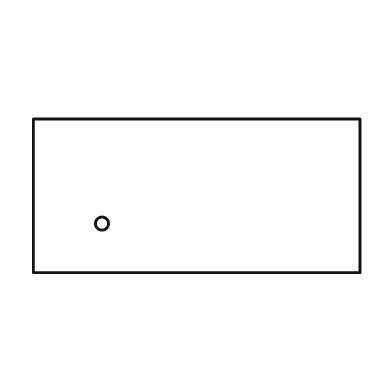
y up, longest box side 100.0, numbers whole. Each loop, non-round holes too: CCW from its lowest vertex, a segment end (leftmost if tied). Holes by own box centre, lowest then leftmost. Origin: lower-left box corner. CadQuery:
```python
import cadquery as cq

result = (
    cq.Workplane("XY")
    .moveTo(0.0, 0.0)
    .lineTo(100.0, 0.0)
    .lineTo(100.0, 47.0)
    .lineTo(0.0, 47.0)
    .close()
    .moveTo(21.0, 15.0)
    .circle(2.0)
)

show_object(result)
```